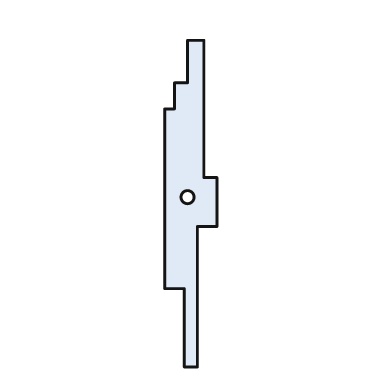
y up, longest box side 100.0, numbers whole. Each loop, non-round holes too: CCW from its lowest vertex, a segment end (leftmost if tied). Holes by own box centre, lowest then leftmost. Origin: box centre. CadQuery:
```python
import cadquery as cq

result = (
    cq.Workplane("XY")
    .moveTo(-2.0, -50.0)
    .lineTo(2.0, -50.0)
    .lineTo(2.0, -7.0)
    .lineTo(8.0, -7.0)
    .lineTo(8.0, 8.0)
    .lineTo(4.0, 8.0)
    .lineTo(4.0, 50.0)
    .lineTo(-1.0, 50.0)
    .lineTo(-1.0, 37.0)
    .lineTo(-5.0, 37.0)
    .lineTo(-5.0, 29.0)
    .lineTo(-8.0, 29.0)
    .lineTo(-8.0, -26.0)
    .lineTo(-2.0, -26.0)
    .close()
    .moveTo(-1.0, 2.0)
    .circle(2.0)
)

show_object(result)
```